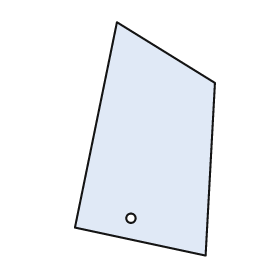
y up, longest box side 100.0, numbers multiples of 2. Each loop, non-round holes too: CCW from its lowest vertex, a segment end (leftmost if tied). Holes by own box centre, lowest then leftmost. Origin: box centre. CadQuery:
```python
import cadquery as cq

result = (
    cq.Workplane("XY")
    .moveTo(26.0, -50.0)
    .lineTo(30.0, 24.0)
    .lineTo(-12.0, 50.0)
    .lineTo(-30.0, -38.0)
    .close()
    .moveTo(-6.0, -34.0)
    .circle(2.0)
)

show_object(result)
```